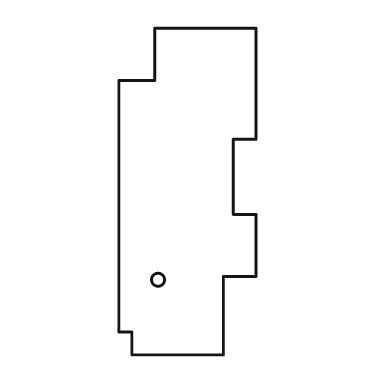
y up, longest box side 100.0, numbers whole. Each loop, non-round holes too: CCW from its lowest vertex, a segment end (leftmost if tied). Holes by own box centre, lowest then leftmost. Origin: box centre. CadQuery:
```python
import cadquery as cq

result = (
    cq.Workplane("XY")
    .moveTo(-17.0, -50.0)
    .lineTo(11.0, -50.0)
    .lineTo(11.0, -26.0)
    .lineTo(21.0, -26.0)
    .lineTo(21.0, -7.0)
    .lineTo(14.0, -7.0)
    .lineTo(14.0, 16.0)
    .lineTo(21.0, 16.0)
    .lineTo(21.0, 50.0)
    .lineTo(-10.0, 50.0)
    .lineTo(-10.0, 34.0)
    .lineTo(-21.0, 34.0)
    .lineTo(-21.0, -43.0)
    .lineTo(-17.0, -43.0)
    .close()
    .moveTo(-9.0, -27.0)
    .circle(2.0)
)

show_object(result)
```